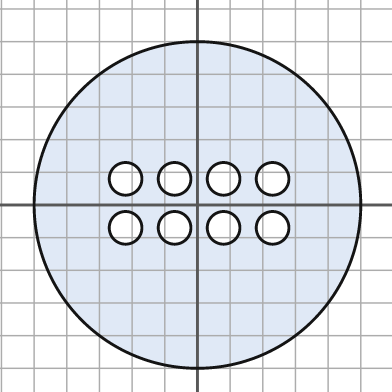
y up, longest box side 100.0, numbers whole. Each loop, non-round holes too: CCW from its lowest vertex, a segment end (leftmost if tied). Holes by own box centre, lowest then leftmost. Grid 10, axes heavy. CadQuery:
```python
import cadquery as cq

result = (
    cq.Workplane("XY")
    .moveTo(0.0, 0.0)
    .circle(50.0)
    .moveTo(-22.0, -7.0)
    .circle(5.0)
    .moveTo(-7.0, -7.0)
    .circle(5.0)
    .moveTo(8.0, -7.0)
    .circle(5.0)
    .moveTo(23.0, -7.0)
    .circle(5.0)
    .moveTo(-22.0, 8.0)
    .circle(5.0)
    .moveTo(-7.0, 8.0)
    .circle(5.0)
    .moveTo(8.0, 8.0)
    .circle(5.0)
    .moveTo(23.0, 8.0)
    .circle(5.0)
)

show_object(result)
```